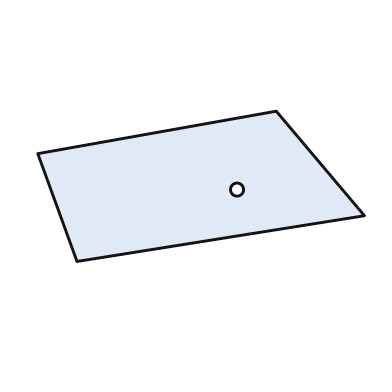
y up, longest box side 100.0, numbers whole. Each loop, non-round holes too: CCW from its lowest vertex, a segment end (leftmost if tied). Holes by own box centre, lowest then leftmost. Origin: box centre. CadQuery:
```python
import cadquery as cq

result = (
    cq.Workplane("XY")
    .moveTo(-38.0, -23.0)
    .lineTo(50.0, -9.0)
    .lineTo(23.0, 23.0)
    .lineTo(-50.0, 10.0)
    .close()
    .moveTo(11.0, -1.0)
    .circle(2.0)
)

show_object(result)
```